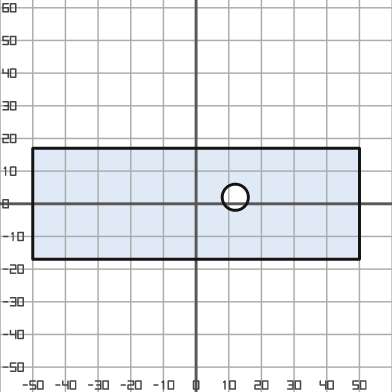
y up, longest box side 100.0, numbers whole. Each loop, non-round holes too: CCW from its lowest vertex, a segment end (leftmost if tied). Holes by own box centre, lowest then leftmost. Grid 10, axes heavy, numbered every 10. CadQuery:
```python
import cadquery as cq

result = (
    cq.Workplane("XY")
    .moveTo(-50.0, -17.0)
    .lineTo(50.0, -17.0)
    .lineTo(50.0, 17.0)
    .lineTo(-50.0, 17.0)
    .close()
    .moveTo(12.0, 2.0)
    .circle(4.0)
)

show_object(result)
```